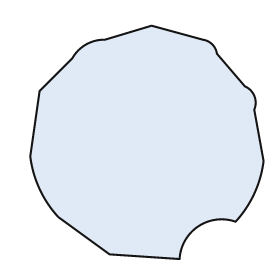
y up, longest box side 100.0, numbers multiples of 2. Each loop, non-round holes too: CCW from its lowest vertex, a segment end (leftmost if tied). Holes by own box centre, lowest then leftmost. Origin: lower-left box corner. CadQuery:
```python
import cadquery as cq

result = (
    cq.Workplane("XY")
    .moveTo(64.0, 0.0)
    .threePointArc((72.0, 14.0), (88.0, 16.0))
    .threePointArc((96.0, 28.0), (100.0, 42.0))
    .lineTo(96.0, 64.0)
    .threePointArc((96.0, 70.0), (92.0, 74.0))
    .lineTo(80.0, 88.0)
    .threePointArc((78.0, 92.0), (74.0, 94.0))
    .lineTo(52.0, 100.0)
    .lineTo(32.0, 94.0)
    .threePointArc((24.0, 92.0), (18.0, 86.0))
    .lineTo(4.0, 72.0)
    .lineTo(0.0, 44.0)
    .threePointArc((4.0, 30.0), (12.0, 18.0))
    .lineTo(34.0, 2.0)
    .close()
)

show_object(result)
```